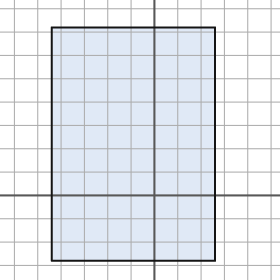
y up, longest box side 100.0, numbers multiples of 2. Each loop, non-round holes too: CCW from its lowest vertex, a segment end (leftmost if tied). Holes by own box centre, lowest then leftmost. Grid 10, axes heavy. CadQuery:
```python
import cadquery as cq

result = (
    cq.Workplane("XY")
    .moveTo(-44.0, -28.0)
    .lineTo(26.0, -28.0)
    .lineTo(26.0, 72.0)
    .lineTo(-44.0, 72.0)
    .close()
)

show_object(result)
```